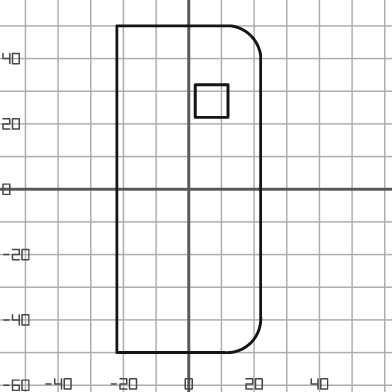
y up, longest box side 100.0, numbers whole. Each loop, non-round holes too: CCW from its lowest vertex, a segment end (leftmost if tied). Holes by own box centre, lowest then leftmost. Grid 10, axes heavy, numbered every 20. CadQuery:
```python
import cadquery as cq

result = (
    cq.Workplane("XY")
    .moveTo(-22.0, -50.0)
    .lineTo(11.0, -50.0)
    .threePointArc((19.0, -47.0), (22.0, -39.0))
    .lineTo(22.0, 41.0)
    .threePointArc((19.0, 47.0), (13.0, 50.0))
    .lineTo(-22.0, 50.0)
    .close()
    .moveTo(2.0, 22.0)
    .lineTo(12.0, 22.0)
    .lineTo(12.0, 32.0)
    .lineTo(2.0, 32.0)
    .close()
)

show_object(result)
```